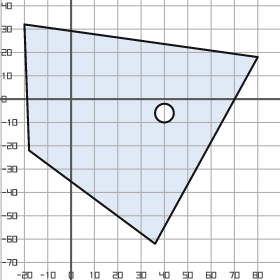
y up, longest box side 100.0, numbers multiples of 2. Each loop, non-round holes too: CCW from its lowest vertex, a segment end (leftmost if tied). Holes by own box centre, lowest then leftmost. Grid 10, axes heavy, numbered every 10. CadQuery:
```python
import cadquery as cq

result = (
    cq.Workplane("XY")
    .moveTo(36.0, -62.0)
    .lineTo(80.0, 18.0)
    .lineTo(-20.0, 32.0)
    .lineTo(-18.0, -22.0)
    .close()
    .moveTo(40.0, -6.0)
    .circle(4.0)
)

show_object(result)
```